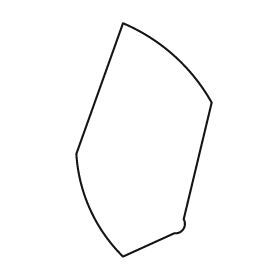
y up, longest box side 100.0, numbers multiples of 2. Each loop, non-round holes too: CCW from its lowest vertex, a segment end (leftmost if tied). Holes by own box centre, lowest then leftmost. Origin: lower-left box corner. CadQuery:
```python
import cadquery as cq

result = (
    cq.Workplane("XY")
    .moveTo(20.0, 0.0)
    .lineTo(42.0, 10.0)
    .threePointArc((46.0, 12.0), (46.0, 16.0))
    .lineTo(58.0, 66.0)
    .threePointArc((42.0, 86.0), (20.0, 100.0))
    .lineTo(0.0, 44.0)
    .threePointArc((6.0, 20.0), (20.0, 0.0))
    .close()
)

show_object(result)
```